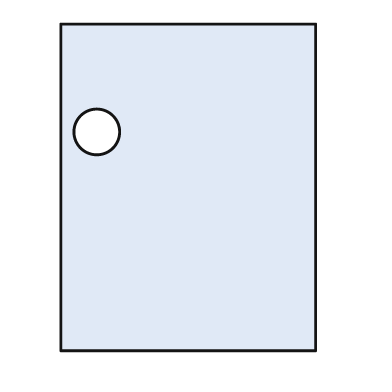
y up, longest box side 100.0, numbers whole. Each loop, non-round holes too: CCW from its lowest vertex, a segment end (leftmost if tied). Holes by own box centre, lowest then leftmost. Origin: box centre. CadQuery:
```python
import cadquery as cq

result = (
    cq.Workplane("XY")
    .moveTo(-39.0, -50.0)
    .lineTo(39.0, -50.0)
    .lineTo(39.0, 50.0)
    .lineTo(-39.0, 50.0)
    .close()
    .moveTo(-28.0, 17.0)
    .circle(7.0)
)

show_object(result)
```